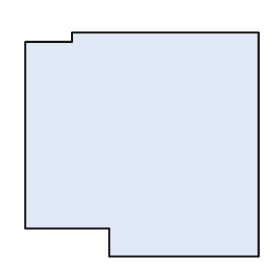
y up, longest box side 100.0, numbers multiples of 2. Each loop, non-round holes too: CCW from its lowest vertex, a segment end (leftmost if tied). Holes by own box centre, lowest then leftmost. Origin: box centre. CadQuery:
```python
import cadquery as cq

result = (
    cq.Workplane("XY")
    .moveTo(-14.0, -48.0)
    .lineTo(50.0, -48.0)
    .lineTo(50.0, 48.0)
    .lineTo(-30.0, 48.0)
    .lineTo(-30.0, 44.0)
    .lineTo(-50.0, 44.0)
    .lineTo(-50.0, -36.0)
    .lineTo(-14.0, -36.0)
    .close()
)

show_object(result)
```